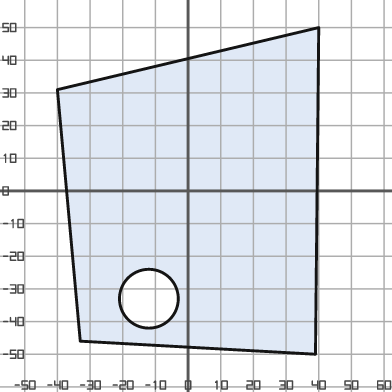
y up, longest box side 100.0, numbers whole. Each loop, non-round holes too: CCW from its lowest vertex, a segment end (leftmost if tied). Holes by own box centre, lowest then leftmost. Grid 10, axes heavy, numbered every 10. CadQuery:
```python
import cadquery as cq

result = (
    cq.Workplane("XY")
    .moveTo(39.0, -50.0)
    .lineTo(40.0, 50.0)
    .lineTo(-40.0, 31.0)
    .lineTo(-33.0, -46.0)
    .close()
    .moveTo(-12.0, -33.0)
    .circle(9.0)
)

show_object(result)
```